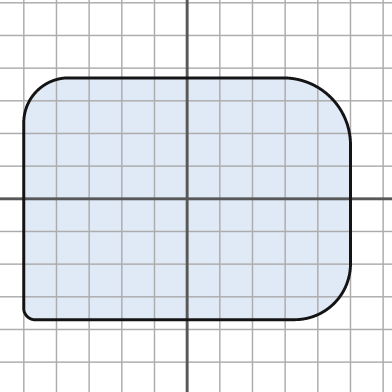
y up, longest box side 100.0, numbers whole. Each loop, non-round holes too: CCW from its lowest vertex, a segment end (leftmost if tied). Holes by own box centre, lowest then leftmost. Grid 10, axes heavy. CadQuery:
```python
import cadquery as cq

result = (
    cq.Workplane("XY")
    .moveTo(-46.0, -37.0)
    .lineTo(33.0, -37.0)
    .threePointArc((45.0, -32.0), (50.0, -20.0))
    .lineTo(50.0, 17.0)
    .threePointArc((44.0, 31.0), (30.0, 37.0))
    .lineTo(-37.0, 37.0)
    .threePointArc((-46.0, 33.0), (-50.0, 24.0))
    .lineTo(-50.0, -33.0)
    .threePointArc((-49.0, -36.0), (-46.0, -37.0))
    .close()
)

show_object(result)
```